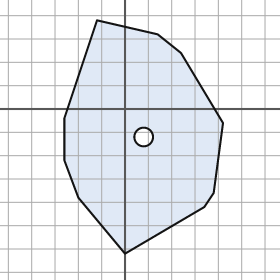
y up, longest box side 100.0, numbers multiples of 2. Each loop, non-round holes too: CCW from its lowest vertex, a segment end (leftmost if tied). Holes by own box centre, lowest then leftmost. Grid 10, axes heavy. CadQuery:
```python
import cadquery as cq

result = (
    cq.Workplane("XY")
    .moveTo(0.0, -62.0)
    .lineTo(34.0, -42.0)
    .lineTo(38.0, -36.0)
    .lineTo(42.0, -6.0)
    .lineTo(24.0, 24.0)
    .lineTo(14.0, 32.0)
    .lineTo(-12.0, 38.0)
    .lineTo(-26.0, -4.0)
    .lineTo(-26.0, -22.0)
    .lineTo(-20.0, -38.0)
    .close()
    .moveTo(8.0, -12.0)
    .circle(4.0)
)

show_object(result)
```